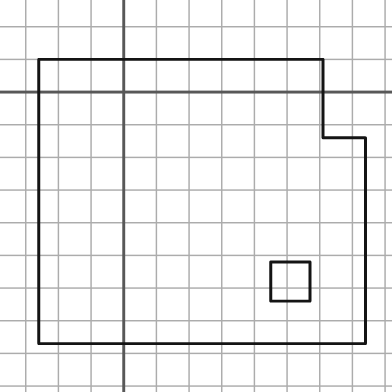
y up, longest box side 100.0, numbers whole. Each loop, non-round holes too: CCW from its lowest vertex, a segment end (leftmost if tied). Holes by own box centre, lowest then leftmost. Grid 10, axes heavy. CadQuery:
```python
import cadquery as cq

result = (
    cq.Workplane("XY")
    .moveTo(-26.0, -77.0)
    .lineTo(74.0, -77.0)
    .lineTo(74.0, -14.0)
    .lineTo(61.0, -14.0)
    .lineTo(61.0, 10.0)
    .lineTo(-26.0, 10.0)
    .close()
    .moveTo(45.0, -64.0)
    .lineTo(57.0, -64.0)
    .lineTo(57.0, -52.0)
    .lineTo(45.0, -52.0)
    .close()
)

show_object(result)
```